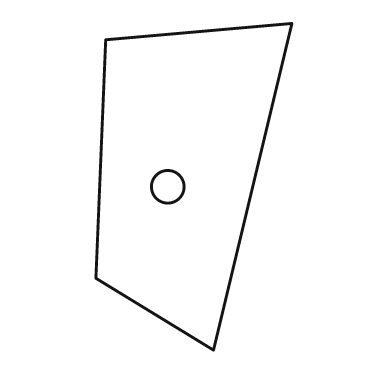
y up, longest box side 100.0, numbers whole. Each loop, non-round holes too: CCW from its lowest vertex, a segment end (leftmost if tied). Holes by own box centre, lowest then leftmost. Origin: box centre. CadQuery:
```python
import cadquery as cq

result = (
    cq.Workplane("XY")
    .moveTo(6.0, -50.0)
    .lineTo(30.0, 50.0)
    .lineTo(-27.0, 45.0)
    .lineTo(-30.0, -28.0)
    .close()
    .moveTo(-8.0, 0.0)
    .circle(5.0)
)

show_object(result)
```